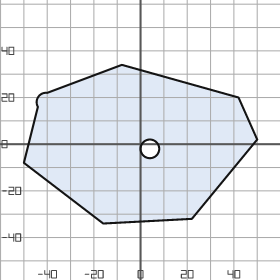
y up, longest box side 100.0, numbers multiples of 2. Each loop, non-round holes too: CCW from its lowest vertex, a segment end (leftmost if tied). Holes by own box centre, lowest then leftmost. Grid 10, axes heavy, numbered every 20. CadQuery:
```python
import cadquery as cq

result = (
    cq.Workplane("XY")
    .moveTo(-16.0, -34.0)
    .lineTo(22.0, -32.0)
    .lineTo(50.0, 2.0)
    .lineTo(42.0, 20.0)
    .lineTo(-8.0, 34.0)
    .lineTo(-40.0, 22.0)
    .threePointArc((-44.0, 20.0), (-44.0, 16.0))
    .lineTo(-50.0, -8.0)
    .close()
    .moveTo(4.0, -2.0)
    .circle(4.0)
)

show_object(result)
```